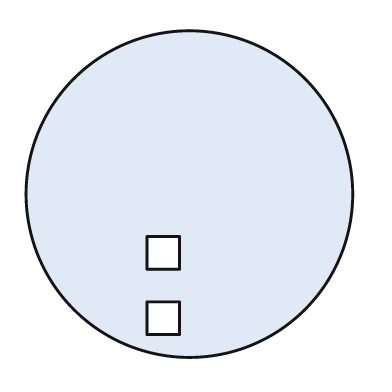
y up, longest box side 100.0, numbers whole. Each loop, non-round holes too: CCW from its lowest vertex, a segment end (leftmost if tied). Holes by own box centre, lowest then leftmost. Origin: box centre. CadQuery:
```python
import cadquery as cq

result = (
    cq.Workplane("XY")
    .moveTo(0.0, 0.0)
    .circle(50.0)
    .moveTo(-13.0, -43.0)
    .lineTo(-3.0, -43.0)
    .lineTo(-3.0, -33.0)
    .lineTo(-13.0, -33.0)
    .close()
    .moveTo(-13.0, -23.0)
    .lineTo(-3.0, -23.0)
    .lineTo(-3.0, -13.0)
    .lineTo(-13.0, -13.0)
    .close()
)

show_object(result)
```